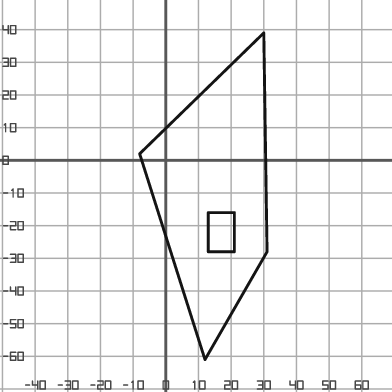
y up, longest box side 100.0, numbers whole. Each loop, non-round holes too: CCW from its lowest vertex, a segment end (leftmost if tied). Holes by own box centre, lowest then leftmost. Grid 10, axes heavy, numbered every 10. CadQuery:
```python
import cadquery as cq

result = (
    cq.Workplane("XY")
    .moveTo(12.0, -61.0)
    .lineTo(31.0, -28.0)
    .lineTo(30.0, 39.0)
    .lineTo(-8.0, 2.0)
    .close()
    .moveTo(13.0, -28.0)
    .lineTo(21.0, -28.0)
    .lineTo(21.0, -16.0)
    .lineTo(13.0, -16.0)
    .close()
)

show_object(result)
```